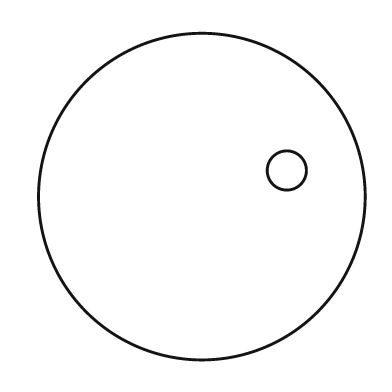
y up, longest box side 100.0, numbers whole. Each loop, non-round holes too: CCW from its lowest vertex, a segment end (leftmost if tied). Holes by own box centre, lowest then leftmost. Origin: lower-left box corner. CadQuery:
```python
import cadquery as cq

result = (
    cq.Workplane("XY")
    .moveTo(50.0, 50.0)
    .circle(50.0)
    .moveTo(76.0, 58.0)
    .circle(6.0)
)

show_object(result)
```